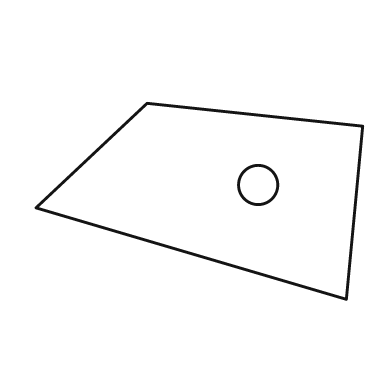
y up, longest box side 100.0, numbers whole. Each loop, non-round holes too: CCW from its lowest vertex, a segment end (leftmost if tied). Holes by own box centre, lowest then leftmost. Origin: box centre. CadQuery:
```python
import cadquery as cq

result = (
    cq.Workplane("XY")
    .moveTo(45.0, -30.0)
    .lineTo(50.0, 23.0)
    .lineTo(-16.0, 30.0)
    .lineTo(-50.0, -2.0)
    .close()
    .moveTo(18.0, 5.0)
    .circle(6.0)
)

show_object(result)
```